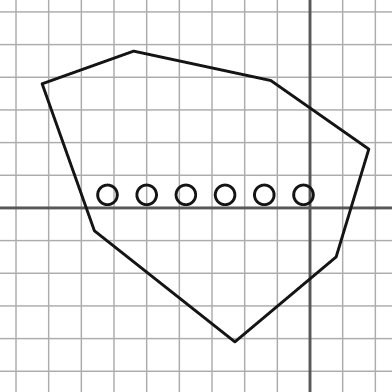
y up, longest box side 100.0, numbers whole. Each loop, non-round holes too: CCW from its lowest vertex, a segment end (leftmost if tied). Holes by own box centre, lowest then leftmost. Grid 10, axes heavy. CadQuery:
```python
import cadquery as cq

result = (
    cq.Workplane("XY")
    .moveTo(-23.0, -41.0)
    .lineTo(8.0, -15.0)
    .lineTo(18.0, 18.0)
    .lineTo(-12.0, 39.0)
    .lineTo(-54.0, 48.0)
    .lineTo(-82.0, 38.0)
    .lineTo(-66.0, -7.0)
    .close()
    .moveTo(-62.0, 4.0)
    .circle(3.0)
    .moveTo(-50.0, 4.0)
    .circle(3.0)
    .moveTo(-38.0, 4.0)
    .circle(3.0)
    .moveTo(-26.0, 4.0)
    .circle(3.0)
    .moveTo(-14.0, 4.0)
    .circle(3.0)
    .moveTo(-2.0, 4.0)
    .circle(3.0)
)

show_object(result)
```